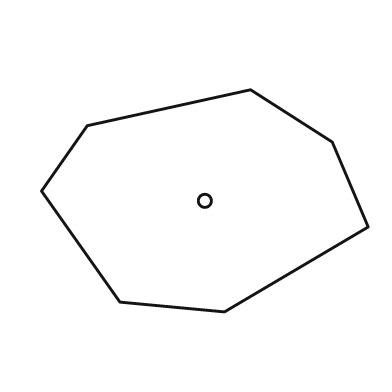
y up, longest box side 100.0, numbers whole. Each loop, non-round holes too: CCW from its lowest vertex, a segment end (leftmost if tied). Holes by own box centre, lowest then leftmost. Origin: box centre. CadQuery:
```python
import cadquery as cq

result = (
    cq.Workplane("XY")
    .moveTo(6.0, -34.0)
    .lineTo(50.0, -8.0)
    .lineTo(39.0, 18.0)
    .lineTo(14.0, 34.0)
    .lineTo(-36.0, 23.0)
    .lineTo(-50.0, 3.0)
    .lineTo(-26.0, -31.0)
    .close()
    .moveTo(0.0, 0.0)
    .circle(2.0)
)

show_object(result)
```